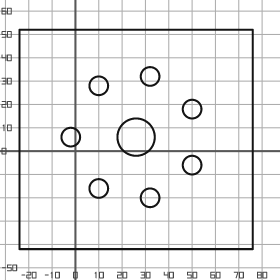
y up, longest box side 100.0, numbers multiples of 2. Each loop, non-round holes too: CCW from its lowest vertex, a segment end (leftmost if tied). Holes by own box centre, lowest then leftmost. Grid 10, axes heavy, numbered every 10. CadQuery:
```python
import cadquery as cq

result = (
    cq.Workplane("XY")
    .moveTo(-24.0, -42.0)
    .lineTo(76.0, -42.0)
    .lineTo(76.0, 52.0)
    .lineTo(-24.0, 52.0)
    .close()
    .moveTo(32.0, -20.0)
    .circle(4.0)
    .moveTo(10.0, -16.0)
    .circle(4.0)
    .moveTo(50.0, -6.0)
    .circle(4.0)
    .moveTo(-2.0, 6.0)
    .circle(4.0)
    .moveTo(26.0, 6.0)
    .circle(8.0)
    .moveTo(50.0, 18.0)
    .circle(4.0)
    .moveTo(10.0, 28.0)
    .circle(4.0)
    .moveTo(32.0, 32.0)
    .circle(4.0)
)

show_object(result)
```